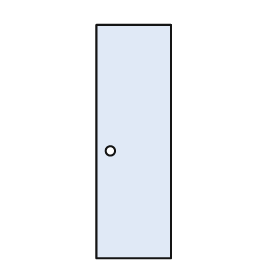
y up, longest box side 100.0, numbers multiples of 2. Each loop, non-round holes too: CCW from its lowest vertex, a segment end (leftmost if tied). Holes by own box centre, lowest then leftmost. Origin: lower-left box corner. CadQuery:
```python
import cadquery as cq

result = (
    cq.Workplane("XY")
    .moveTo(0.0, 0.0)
    .lineTo(32.0, 0.0)
    .lineTo(32.0, 100.0)
    .lineTo(0.0, 100.0)
    .close()
    .moveTo(6.0, 46.0)
    .circle(2.0)
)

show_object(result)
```